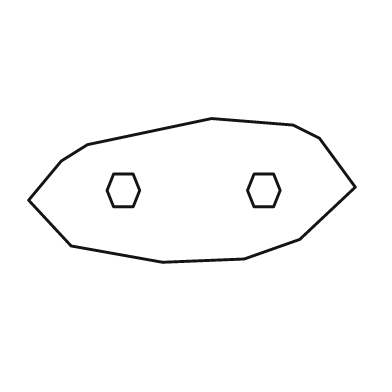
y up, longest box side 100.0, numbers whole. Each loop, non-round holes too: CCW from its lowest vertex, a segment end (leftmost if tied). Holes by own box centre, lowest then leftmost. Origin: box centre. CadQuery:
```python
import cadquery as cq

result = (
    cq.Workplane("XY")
    .moveTo(-9.0, -22.0)
    .lineTo(16.0, -21.0)
    .lineTo(33.0, -15.0)
    .lineTo(50.0, 1.0)
    .lineTo(39.0, 16.0)
    .lineTo(31.0, 20.0)
    .lineTo(6.0, 22.0)
    .lineTo(-32.0, 14.0)
    .lineTo(-40.0, 9.0)
    .lineTo(-50.0, -3.0)
    .lineTo(-37.0, -17.0)
    .close()
    .moveTo(-24.0, -5.0)
    .lineTo(-18.0, -5.0)
    .lineTo(-16.0, 0.0)
    .lineTo(-18.0, 5.0)
    .lineTo(-24.0, 5.0)
    .lineTo(-26.0, 0.0)
    .close()
    .moveTo(19.0, -5.0)
    .lineTo(25.0, -5.0)
    .lineTo(27.0, 0.0)
    .lineTo(25.0, 5.0)
    .lineTo(19.0, 5.0)
    .lineTo(17.0, 0.0)
    .close()
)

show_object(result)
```